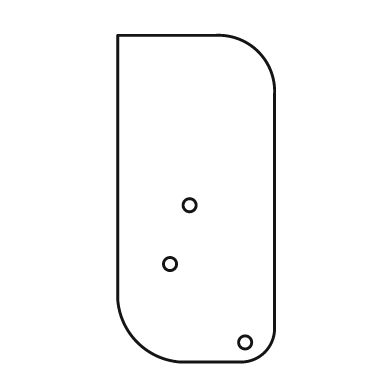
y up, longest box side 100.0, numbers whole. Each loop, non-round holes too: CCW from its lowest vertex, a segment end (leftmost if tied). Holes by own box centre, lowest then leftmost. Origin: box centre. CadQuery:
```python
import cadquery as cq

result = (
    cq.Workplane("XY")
    .moveTo(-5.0, -50.0)
    .lineTo(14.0, -50.0)
    .threePointArc((21.0, -47.0), (24.0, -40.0))
    .lineTo(24.0, 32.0)
    .threePointArc((19.0, 45.0), (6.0, 50.0))
    .lineTo(-24.0, 50.0)
    .lineTo(-24.0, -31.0)
    .threePointArc((-18.0, -44.0), (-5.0, -50.0))
    .close()
    .moveTo(15.0, -44.0)
    .circle(2.0)
    .moveTo(-8.0, -20.0)
    .circle(2.0)
    .moveTo(-2.0, -2.0)
    .circle(2.0)
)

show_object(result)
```